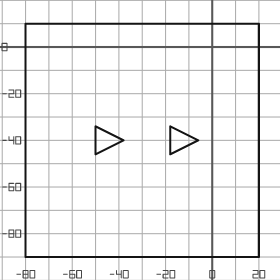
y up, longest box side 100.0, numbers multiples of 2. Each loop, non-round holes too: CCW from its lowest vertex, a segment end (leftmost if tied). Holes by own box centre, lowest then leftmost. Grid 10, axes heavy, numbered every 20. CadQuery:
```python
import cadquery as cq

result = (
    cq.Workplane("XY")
    .moveTo(-80.0, -90.0)
    .lineTo(20.0, -90.0)
    .lineTo(20.0, 10.0)
    .lineTo(-80.0, 10.0)
    .close()
    .moveTo(-50.0, -46.0)
    .lineTo(-38.0, -40.0)
    .lineTo(-50.0, -34.0)
    .close()
    .moveTo(-18.0, -46.0)
    .lineTo(-6.0, -40.0)
    .lineTo(-18.0, -34.0)
    .close()
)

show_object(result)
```